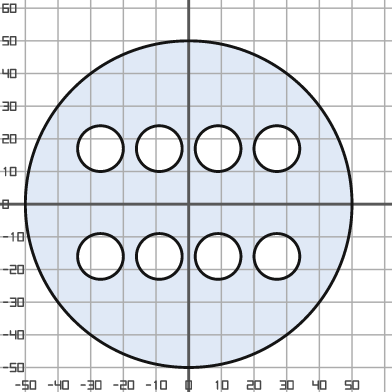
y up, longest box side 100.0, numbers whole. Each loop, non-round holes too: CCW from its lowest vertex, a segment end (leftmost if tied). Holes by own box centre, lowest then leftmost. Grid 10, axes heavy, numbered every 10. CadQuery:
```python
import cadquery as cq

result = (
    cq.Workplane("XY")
    .moveTo(0.0, 0.0)
    .circle(50.0)
    .moveTo(-27.0, -16.0)
    .circle(7.0)
    .moveTo(-9.0, -16.0)
    .circle(7.0)
    .moveTo(9.0, -16.0)
    .circle(7.0)
    .moveTo(27.0, -16.0)
    .circle(7.0)
    .moveTo(-27.0, 17.0)
    .circle(7.0)
    .moveTo(-9.0, 17.0)
    .circle(7.0)
    .moveTo(9.0, 17.0)
    .circle(7.0)
    .moveTo(27.0, 17.0)
    .circle(7.0)
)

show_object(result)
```